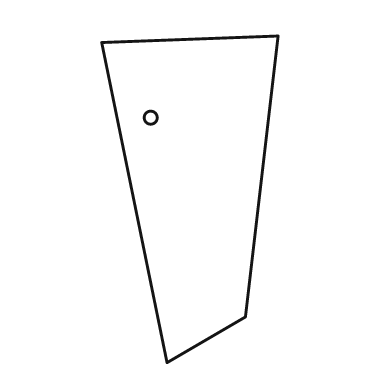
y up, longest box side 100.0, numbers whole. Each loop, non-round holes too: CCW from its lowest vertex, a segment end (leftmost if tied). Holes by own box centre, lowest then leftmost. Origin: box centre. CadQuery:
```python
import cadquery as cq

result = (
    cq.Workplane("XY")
    .moveTo(-7.0, -50.0)
    .lineTo(17.0, -36.0)
    .lineTo(27.0, 50.0)
    .lineTo(-27.0, 48.0)
    .close()
    .moveTo(-12.0, 25.0)
    .circle(2.0)
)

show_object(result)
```